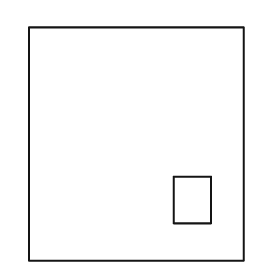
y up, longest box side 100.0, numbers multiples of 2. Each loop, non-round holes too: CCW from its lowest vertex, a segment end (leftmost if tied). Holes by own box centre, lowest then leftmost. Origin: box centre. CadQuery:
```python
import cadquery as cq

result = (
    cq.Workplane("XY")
    .moveTo(-46.0, -50.0)
    .lineTo(46.0, -50.0)
    .lineTo(46.0, 50.0)
    .lineTo(-46.0, 50.0)
    .close()
    .moveTo(16.0, -34.0)
    .lineTo(32.0, -34.0)
    .lineTo(32.0, -14.0)
    .lineTo(16.0, -14.0)
    .close()
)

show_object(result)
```